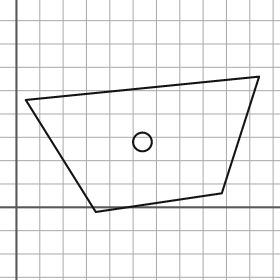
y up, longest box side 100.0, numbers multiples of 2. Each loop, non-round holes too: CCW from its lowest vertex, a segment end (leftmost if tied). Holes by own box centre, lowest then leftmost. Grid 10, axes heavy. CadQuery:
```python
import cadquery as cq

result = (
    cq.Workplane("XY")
    .moveTo(34.0, -2.0)
    .lineTo(88.0, 6.0)
    .lineTo(104.0, 56.0)
    .lineTo(4.0, 46.0)
    .close()
    .moveTo(54.0, 28.0)
    .circle(4.0)
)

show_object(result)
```